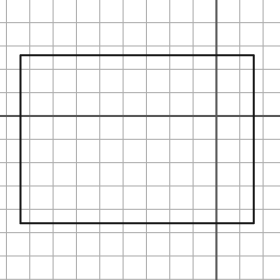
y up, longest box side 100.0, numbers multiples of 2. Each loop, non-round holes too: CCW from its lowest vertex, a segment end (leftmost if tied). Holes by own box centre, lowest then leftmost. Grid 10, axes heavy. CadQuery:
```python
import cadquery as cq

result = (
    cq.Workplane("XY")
    .moveTo(-84.0, -46.0)
    .lineTo(16.0, -46.0)
    .lineTo(16.0, 26.0)
    .lineTo(-84.0, 26.0)
    .close()
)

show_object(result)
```